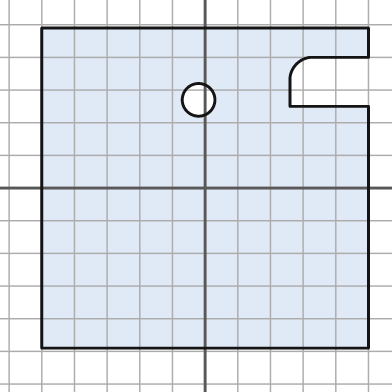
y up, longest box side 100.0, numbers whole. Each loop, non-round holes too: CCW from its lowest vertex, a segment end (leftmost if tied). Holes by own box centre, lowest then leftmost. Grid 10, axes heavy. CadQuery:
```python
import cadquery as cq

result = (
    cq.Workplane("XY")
    .moveTo(-50.0, -49.0)
    .lineTo(50.0, -49.0)
    .lineTo(50.0, 25.0)
    .lineTo(26.0, 25.0)
    .lineTo(26.0, 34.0)
    .threePointArc((28.0, 38.0), (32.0, 40.0))
    .lineTo(50.0, 40.0)
    .lineTo(50.0, 49.0)
    .lineTo(-50.0, 49.0)
    .close()
    .moveTo(-2.0, 27.0)
    .circle(5.0)
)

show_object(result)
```